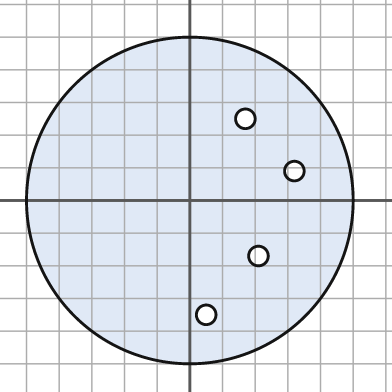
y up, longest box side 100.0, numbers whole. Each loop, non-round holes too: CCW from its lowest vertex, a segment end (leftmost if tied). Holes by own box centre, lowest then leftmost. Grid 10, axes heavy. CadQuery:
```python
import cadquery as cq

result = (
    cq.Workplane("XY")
    .moveTo(0.0, 0.0)
    .circle(50.0)
    .moveTo(5.0, -35.0)
    .circle(3.0)
    .moveTo(21.0, -17.0)
    .circle(3.0)
    .moveTo(32.0, 9.0)
    .circle(3.0)
    .moveTo(17.0, 25.0)
    .circle(3.0)
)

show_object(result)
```